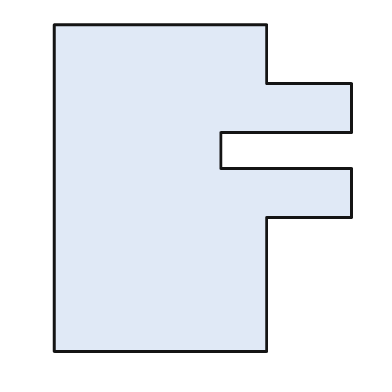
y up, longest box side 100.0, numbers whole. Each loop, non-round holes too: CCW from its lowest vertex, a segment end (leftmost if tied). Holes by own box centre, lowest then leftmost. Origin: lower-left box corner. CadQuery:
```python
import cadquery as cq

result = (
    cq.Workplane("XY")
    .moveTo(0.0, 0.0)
    .lineTo(65.0, 0.0)
    .lineTo(65.0, 41.0)
    .lineTo(91.0, 41.0)
    .lineTo(91.0, 56.0)
    .lineTo(51.0, 56.0)
    .lineTo(51.0, 67.0)
    .lineTo(91.0, 67.0)
    .lineTo(91.0, 82.0)
    .lineTo(65.0, 82.0)
    .lineTo(65.0, 100.0)
    .lineTo(0.0, 100.0)
    .close()
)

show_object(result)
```